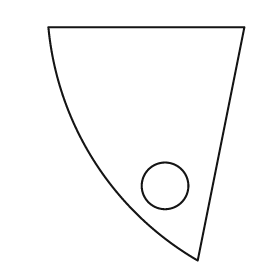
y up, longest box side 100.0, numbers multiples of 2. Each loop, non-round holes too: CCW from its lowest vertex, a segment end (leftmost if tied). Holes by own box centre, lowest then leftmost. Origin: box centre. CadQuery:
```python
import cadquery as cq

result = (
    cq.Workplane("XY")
    .moveTo(22.0, -50.0)
    .lineTo(42.0, 50.0)
    .lineTo(-42.0, 50.0)
    .threePointArc((-22.0, -8.0), (22.0, -50.0))
    .close()
    .moveTo(8.0, -18.0)
    .circle(10.0)
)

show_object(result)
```